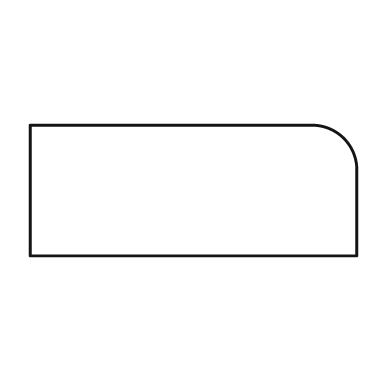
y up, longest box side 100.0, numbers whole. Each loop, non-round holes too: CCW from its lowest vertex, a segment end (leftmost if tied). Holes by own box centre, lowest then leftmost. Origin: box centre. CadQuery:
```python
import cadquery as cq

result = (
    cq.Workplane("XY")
    .moveTo(-50.0, -20.0)
    .lineTo(50.0, -20.0)
    .lineTo(50.0, 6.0)
    .threePointArc((46.0, 16.0), (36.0, 20.0))
    .lineTo(-50.0, 20.0)
    .close()
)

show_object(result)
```